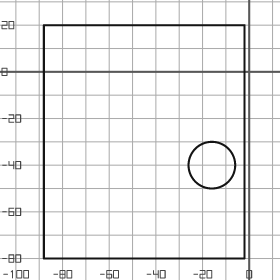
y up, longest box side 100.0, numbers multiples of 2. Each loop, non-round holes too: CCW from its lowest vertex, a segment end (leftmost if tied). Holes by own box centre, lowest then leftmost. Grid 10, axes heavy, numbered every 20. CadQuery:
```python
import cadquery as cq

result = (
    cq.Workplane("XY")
    .moveTo(-88.0, -80.0)
    .lineTo(-2.0, -80.0)
    .lineTo(-2.0, 20.0)
    .lineTo(-88.0, 20.0)
    .close()
    .moveTo(-16.0, -40.0)
    .circle(10.0)
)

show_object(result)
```